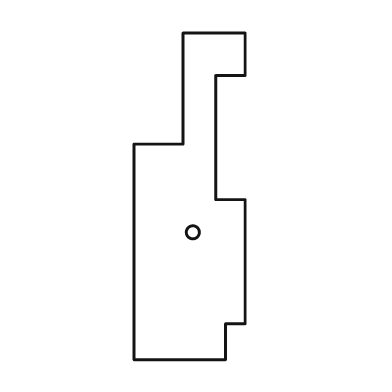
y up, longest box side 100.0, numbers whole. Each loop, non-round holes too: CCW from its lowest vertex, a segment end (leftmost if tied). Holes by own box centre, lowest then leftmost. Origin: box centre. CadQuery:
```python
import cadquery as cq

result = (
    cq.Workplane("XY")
    .moveTo(-17.0, -50.0)
    .lineTo(11.0, -50.0)
    .lineTo(11.0, -39.0)
    .lineTo(17.0, -39.0)
    .lineTo(17.0, -1.0)
    .lineTo(8.0, -1.0)
    .lineTo(8.0, 37.0)
    .lineTo(17.0, 37.0)
    .lineTo(17.0, 50.0)
    .lineTo(-2.0, 50.0)
    .lineTo(-2.0, 16.0)
    .lineTo(-17.0, 16.0)
    .close()
    .moveTo(1.0, -11.0)
    .circle(2.0)
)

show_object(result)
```